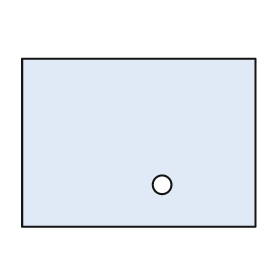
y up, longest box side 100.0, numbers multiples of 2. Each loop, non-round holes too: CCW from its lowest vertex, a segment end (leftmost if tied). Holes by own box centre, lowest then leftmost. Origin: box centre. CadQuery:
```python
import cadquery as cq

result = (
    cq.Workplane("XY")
    .moveTo(-50.0, -36.0)
    .lineTo(50.0, -36.0)
    .lineTo(50.0, 36.0)
    .lineTo(-50.0, 36.0)
    .close()
    .moveTo(10.0, -18.0)
    .circle(4.0)
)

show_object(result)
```